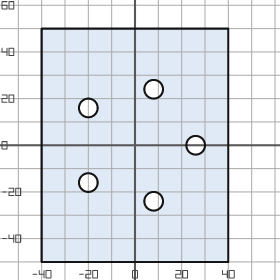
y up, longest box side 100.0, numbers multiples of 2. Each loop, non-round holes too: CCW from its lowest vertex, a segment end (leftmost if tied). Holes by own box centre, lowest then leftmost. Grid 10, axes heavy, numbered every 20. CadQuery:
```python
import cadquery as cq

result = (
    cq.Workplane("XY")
    .moveTo(-40.0, -50.0)
    .lineTo(40.0, -50.0)
    .lineTo(40.0, 50.0)
    .lineTo(-40.0, 50.0)
    .close()
    .moveTo(8.0, -24.0)
    .circle(4.0)
    .moveTo(-20.0, -16.0)
    .circle(4.0)
    .moveTo(26.0, 0.0)
    .circle(4.0)
    .moveTo(-20.0, 16.0)
    .circle(4.0)
    .moveTo(8.0, 24.0)
    .circle(4.0)
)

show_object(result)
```